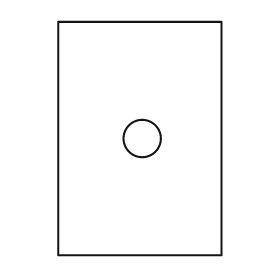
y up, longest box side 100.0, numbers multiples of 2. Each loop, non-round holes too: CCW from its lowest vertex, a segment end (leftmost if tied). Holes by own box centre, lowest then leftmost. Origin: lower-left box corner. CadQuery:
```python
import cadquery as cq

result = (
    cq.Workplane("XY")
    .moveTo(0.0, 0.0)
    .lineTo(70.0, 0.0)
    .lineTo(70.0, 100.0)
    .lineTo(0.0, 100.0)
    .close()
    .moveTo(36.0, 50.0)
    .circle(8.0)
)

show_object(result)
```